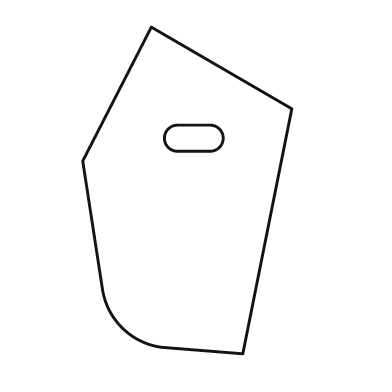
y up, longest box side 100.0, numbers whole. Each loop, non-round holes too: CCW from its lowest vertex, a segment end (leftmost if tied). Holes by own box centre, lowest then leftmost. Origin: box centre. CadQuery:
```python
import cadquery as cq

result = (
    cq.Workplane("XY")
    .moveTo(17.0, -50.0)
    .lineTo(32.0, 25.0)
    .lineTo(-11.0, 50.0)
    .lineTo(-32.0, 9.0)
    .lineTo(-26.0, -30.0)
    .threePointArc((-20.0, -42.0), (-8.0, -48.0))
    .close()
    .moveTo(-3.0, 12.0)
    .lineTo(7.0, 12.0)
    .threePointArc((11.0, 16.0), (7.0, 20.0))
    .lineTo(-3.0, 20.0)
    .threePointArc((-7.0, 16.0), (-3.0, 12.0))
    .close()
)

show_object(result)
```